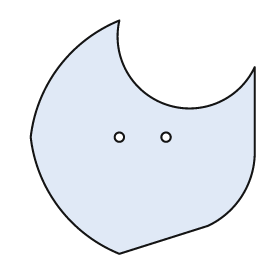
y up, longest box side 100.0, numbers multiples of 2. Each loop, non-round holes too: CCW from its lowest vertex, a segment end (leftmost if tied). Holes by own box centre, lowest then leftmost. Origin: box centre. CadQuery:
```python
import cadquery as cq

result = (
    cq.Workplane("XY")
    .moveTo(-10.0, -50.0)
    .lineTo(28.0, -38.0)
    .threePointArc((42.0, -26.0), (48.0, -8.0))
    .lineTo(48.0, 30.0)
    .threePointArc((10.0, 14.0), (-10.0, 50.0))
    .threePointArc((-36.0, 30.0), (-48.0, 0.0))
    .threePointArc((-36.0, -30.0), (-10.0, -50.0))
    .close()
    .moveTo(-10.0, 0.0)
    .circle(2.0)
    .moveTo(10.0, 0.0)
    .circle(2.0)
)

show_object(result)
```